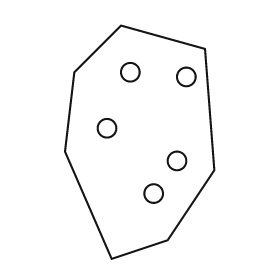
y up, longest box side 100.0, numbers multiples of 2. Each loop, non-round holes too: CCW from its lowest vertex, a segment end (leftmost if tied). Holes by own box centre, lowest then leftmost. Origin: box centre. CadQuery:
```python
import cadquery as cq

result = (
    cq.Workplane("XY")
    .moveTo(-12.0, -50.0)
    .lineTo(12.0, -42.0)
    .lineTo(32.0, -12.0)
    .lineTo(28.0, 40.0)
    .lineTo(-8.0, 50.0)
    .lineTo(-28.0, 30.0)
    .lineTo(-32.0, -4.0)
    .close()
    .moveTo(6.0, -22.0)
    .circle(4.0)
    .moveTo(16.0, -8.0)
    .circle(4.0)
    .moveTo(-14.0, 6.0)
    .circle(4.0)
    .moveTo(20.0, 28.0)
    .circle(4.0)
    .moveTo(-4.0, 30.0)
    .circle(4.0)
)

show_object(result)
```